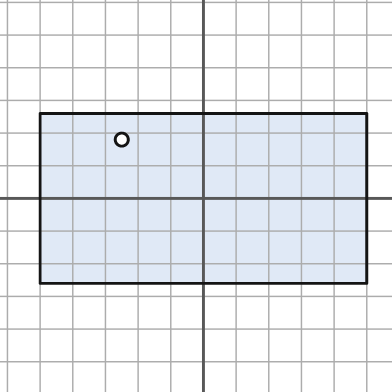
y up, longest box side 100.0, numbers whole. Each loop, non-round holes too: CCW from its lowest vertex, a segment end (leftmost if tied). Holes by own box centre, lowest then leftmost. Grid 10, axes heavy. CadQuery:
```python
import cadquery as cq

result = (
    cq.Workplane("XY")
    .moveTo(-50.0, -26.0)
    .lineTo(50.0, -26.0)
    .lineTo(50.0, 26.0)
    .lineTo(-50.0, 26.0)
    .close()
    .moveTo(-25.0, 18.0)
    .circle(2.0)
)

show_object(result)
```